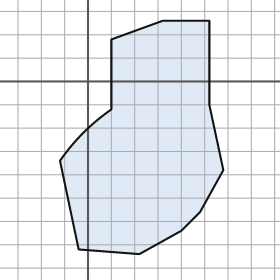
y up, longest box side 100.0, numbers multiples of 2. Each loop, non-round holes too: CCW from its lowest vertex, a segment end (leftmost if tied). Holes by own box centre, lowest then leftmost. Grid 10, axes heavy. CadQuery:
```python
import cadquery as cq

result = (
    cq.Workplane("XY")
    .moveTo(22.0, -74.0)
    .lineTo(40.0, -64.0)
    .lineTo(48.0, -56.0)
    .lineTo(58.0, -38.0)
    .lineTo(52.0, -10.0)
    .lineTo(52.0, 26.0)
    .lineTo(32.0, 26.0)
    .lineTo(10.0, 18.0)
    .lineTo(10.0, -12.0)
    .threePointArc((-2.0, -22.0), (-12.0, -34.0))
    .lineTo(-4.0, -72.0)
    .close()
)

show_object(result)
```